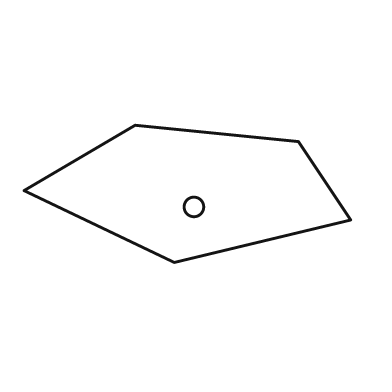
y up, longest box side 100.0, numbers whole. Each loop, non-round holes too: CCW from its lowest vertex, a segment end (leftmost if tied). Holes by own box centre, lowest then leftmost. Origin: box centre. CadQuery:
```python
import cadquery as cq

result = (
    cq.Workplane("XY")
    .moveTo(-4.0, -21.0)
    .lineTo(50.0, -8.0)
    .lineTo(34.0, 16.0)
    .lineTo(-16.0, 21.0)
    .lineTo(-50.0, 1.0)
    .close()
    .moveTo(2.0, -4.0)
    .circle(3.0)
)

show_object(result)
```